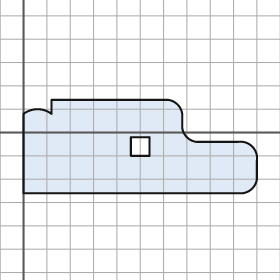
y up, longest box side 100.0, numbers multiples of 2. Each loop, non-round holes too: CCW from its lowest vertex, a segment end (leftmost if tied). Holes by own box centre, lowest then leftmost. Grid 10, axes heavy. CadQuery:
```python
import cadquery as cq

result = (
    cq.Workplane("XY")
    .moveTo(0.0, -26.0)
    .lineTo(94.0, -26.0)
    .threePointArc((98.0, -24.0), (100.0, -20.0))
    .lineTo(100.0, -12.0)
    .threePointArc((98.0, -6.0), (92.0, -4.0))
    .lineTo(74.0, -4.0)
    .threePointArc((70.0, -2.0), (68.0, 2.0))
    .lineTo(68.0, 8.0)
    .threePointArc((66.0, 12.0), (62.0, 14.0))
    .lineTo(12.0, 14.0)
    .lineTo(12.0, 8.0)
    .threePointArc((6.0, 10.0), (0.0, 8.0))
    .close()
    .moveTo(46.0, -10.0)
    .lineTo(54.0, -10.0)
    .lineTo(54.0, -2.0)
    .lineTo(46.0, -2.0)
    .close()
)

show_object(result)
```